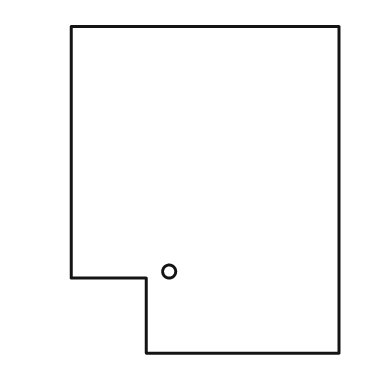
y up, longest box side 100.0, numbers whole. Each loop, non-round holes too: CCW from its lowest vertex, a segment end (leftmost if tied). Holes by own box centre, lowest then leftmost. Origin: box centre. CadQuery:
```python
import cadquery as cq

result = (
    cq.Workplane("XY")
    .moveTo(-18.0, -50.0)
    .lineTo(41.0, -50.0)
    .lineTo(41.0, 50.0)
    .lineTo(-41.0, 50.0)
    .lineTo(-41.0, -27.0)
    .lineTo(-18.0, -27.0)
    .close()
    .moveTo(-11.0, -25.0)
    .circle(2.0)
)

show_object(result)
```